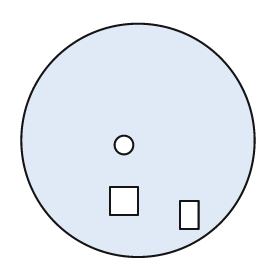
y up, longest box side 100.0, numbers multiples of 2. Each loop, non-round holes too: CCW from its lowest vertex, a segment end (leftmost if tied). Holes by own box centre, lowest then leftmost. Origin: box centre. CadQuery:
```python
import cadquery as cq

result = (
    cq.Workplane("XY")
    .moveTo(0.0, 0.0)
    .circle(50.0)
    .moveTo(18.0, -38.0)
    .lineTo(26.0, -38.0)
    .lineTo(26.0, -26.0)
    .lineTo(18.0, -26.0)
    .close()
    .moveTo(-12.0, -32.0)
    .lineTo(0.0, -32.0)
    .lineTo(0.0, -20.0)
    .lineTo(-12.0, -20.0)
    .close()
    .moveTo(-6.0, -2.0)
    .circle(4.0)
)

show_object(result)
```